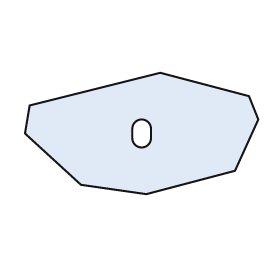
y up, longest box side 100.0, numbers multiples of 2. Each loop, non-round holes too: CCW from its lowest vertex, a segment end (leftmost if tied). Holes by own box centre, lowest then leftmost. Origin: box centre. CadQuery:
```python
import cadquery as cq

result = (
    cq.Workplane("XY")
    .moveTo(2.0, -26.0)
    .lineTo(40.0, -16.0)
    .lineTo(50.0, 6.0)
    .lineTo(46.0, 16.0)
    .lineTo(8.0, 26.0)
    .lineTo(-48.0, 12.0)
    .lineTo(-50.0, 0.0)
    .lineTo(-26.0, -22.0)
    .close()
    .moveTo(-4.0, -2.0)
    .threePointArc((0.0, -6.0), (4.0, -2.0))
    .lineTo(4.0, 2.0)
    .threePointArc((0.0, 6.0), (-4.0, 2.0))
    .close()
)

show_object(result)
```